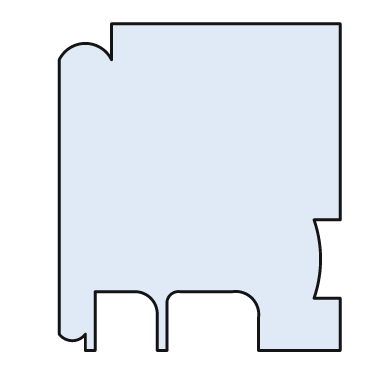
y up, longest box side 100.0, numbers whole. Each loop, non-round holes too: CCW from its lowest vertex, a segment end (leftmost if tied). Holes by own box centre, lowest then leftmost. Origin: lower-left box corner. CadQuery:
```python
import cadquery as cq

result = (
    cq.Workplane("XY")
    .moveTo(8.0, 0.0)
    .lineTo(11.0, 0.0)
    .lineTo(11.0, 18.0)
    .lineTo(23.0, 18.0)
    .threePointArc((28.0, 16.0), (30.0, 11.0))
    .lineTo(30.0, 0.0)
    .lineTo(33.0, 0.0)
    .lineTo(33.0, 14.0)
    .threePointArc((34.0, 17.0), (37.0, 18.0))
    .lineTo(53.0, 18.0)
    .threePointArc((59.0, 16.0), (61.0, 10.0))
    .lineTo(61.0, 0.0)
    .lineTo(86.0, 0.0)
    .lineTo(86.0, 16.0)
    .lineTo(78.0, 16.0)
    .threePointArc((80.0, 28.0), (78.0, 40.0))
    .lineTo(86.0, 40.0)
    .lineTo(86.0, 100.0)
    .lineTo(16.0, 100.0)
    .lineTo(16.0, 89.0)
    .threePointArc((8.0, 94.0), (0.0, 89.0))
    .lineTo(0.0, 5.0)
    .threePointArc((4.0, 3.0), (8.0, 5.0))
    .close()
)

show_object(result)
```